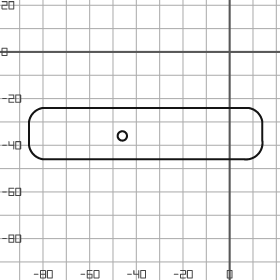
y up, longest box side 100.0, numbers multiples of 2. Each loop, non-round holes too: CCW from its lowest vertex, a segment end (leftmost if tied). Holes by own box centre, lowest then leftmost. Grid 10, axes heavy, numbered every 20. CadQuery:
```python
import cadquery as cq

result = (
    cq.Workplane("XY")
    .moveTo(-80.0, -46.0)
    .lineTo(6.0, -46.0)
    .threePointArc((12.0, -44.0), (14.0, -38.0))
    .lineTo(14.0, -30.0)
    .threePointArc((12.0, -26.0), (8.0, -24.0))
    .lineTo(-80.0, -24.0)
    .threePointArc((-84.0, -26.0), (-86.0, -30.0))
    .lineTo(-86.0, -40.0)
    .threePointArc((-84.0, -44.0), (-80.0, -46.0))
    .close()
    .moveTo(-46.0, -36.0)
    .circle(2.0)
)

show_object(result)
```